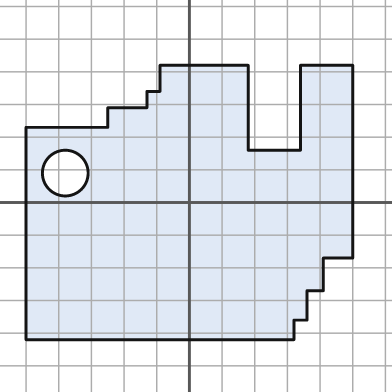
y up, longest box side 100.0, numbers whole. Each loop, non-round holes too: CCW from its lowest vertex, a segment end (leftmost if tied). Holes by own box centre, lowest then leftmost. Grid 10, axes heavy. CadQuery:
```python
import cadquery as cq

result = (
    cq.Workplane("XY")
    .moveTo(-50.0, -42.0)
    .lineTo(32.0, -42.0)
    .lineTo(32.0, -36.0)
    .lineTo(36.0, -36.0)
    .lineTo(36.0, -27.0)
    .lineTo(41.0, -27.0)
    .lineTo(41.0, -17.0)
    .lineTo(50.0, -17.0)
    .lineTo(50.0, 42.0)
    .lineTo(34.0, 42.0)
    .lineTo(34.0, 16.0)
    .lineTo(18.0, 16.0)
    .lineTo(18.0, 42.0)
    .lineTo(-9.0, 42.0)
    .lineTo(-9.0, 34.0)
    .lineTo(-13.0, 34.0)
    .lineTo(-13.0, 29.0)
    .lineTo(-25.0, 29.0)
    .lineTo(-25.0, 23.0)
    .lineTo(-50.0, 23.0)
    .close()
    .moveTo(-38.0, 9.0)
    .circle(7.0)
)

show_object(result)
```